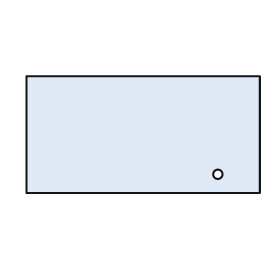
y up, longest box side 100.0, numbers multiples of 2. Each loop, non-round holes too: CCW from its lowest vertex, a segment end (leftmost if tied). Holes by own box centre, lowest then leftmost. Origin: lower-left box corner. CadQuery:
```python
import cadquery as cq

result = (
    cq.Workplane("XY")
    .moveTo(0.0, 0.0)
    .lineTo(100.0, 0.0)
    .lineTo(100.0, 50.0)
    .lineTo(0.0, 50.0)
    .close()
    .moveTo(82.0, 8.0)
    .circle(2.0)
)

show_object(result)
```